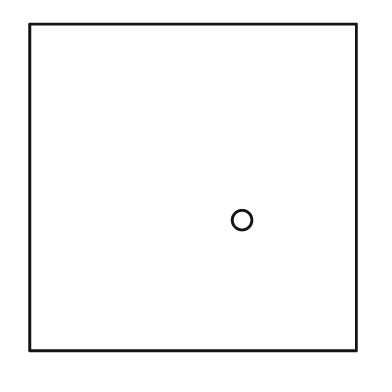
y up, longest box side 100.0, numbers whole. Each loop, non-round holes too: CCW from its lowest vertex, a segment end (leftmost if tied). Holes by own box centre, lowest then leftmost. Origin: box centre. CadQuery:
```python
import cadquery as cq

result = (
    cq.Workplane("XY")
    .moveTo(-50.0, -50.0)
    .lineTo(50.0, -50.0)
    .lineTo(50.0, 50.0)
    .lineTo(-50.0, 50.0)
    .close()
    .moveTo(15.0, -10.0)
    .circle(3.0)
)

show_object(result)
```